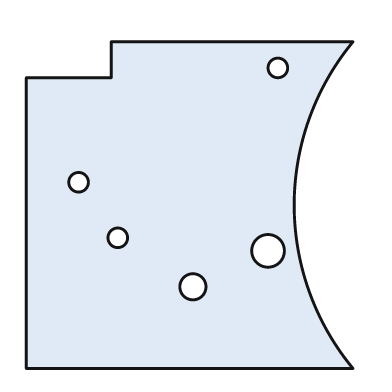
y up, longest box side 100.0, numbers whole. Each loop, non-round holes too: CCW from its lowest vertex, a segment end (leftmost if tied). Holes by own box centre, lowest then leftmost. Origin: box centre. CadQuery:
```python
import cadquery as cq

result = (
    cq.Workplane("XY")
    .moveTo(-50.0, -50.0)
    .lineTo(50.0, -50.0)
    .threePointArc((32.0, 0.0), (50.0, 50.0))
    .lineTo(-24.0, 50.0)
    .lineTo(-24.0, 39.0)
    .lineTo(-50.0, 39.0)
    .close()
    .moveTo(1.0, -25.0)
    .circle(4.0)
    .moveTo(24.0, -14.0)
    .circle(5.0)
    .moveTo(-22.0, -10.0)
    .circle(3.0)
    .moveTo(-34.0, 7.0)
    .circle(3.0)
    .moveTo(27.0, 42.0)
    .circle(3.0)
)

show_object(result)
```